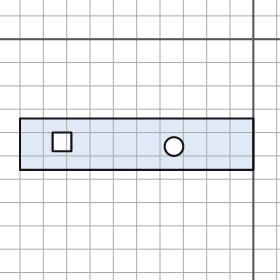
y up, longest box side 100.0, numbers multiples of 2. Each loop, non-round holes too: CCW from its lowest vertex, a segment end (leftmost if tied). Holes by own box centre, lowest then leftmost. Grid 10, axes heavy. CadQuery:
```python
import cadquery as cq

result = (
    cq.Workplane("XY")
    .moveTo(-100.0, -56.0)
    .lineTo(0.0, -56.0)
    .lineTo(0.0, -34.0)
    .lineTo(-100.0, -34.0)
    .close()
    .moveTo(-34.0, -46.0)
    .circle(4.0)
    .moveTo(-86.0, -48.0)
    .lineTo(-78.0, -48.0)
    .lineTo(-78.0, -40.0)
    .lineTo(-86.0, -40.0)
    .close()
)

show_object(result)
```